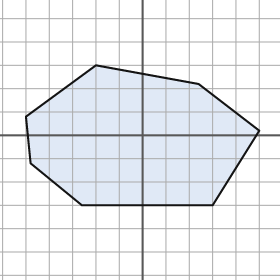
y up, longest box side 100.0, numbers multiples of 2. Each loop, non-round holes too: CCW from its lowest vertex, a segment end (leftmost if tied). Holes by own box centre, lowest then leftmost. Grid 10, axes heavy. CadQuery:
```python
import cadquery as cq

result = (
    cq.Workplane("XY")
    .moveTo(-26.0, -30.0)
    .lineTo(30.0, -30.0)
    .lineTo(50.0, 2.0)
    .lineTo(24.0, 22.0)
    .lineTo(-20.0, 30.0)
    .lineTo(-50.0, 8.0)
    .lineTo(-48.0, -12.0)
    .close()
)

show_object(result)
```